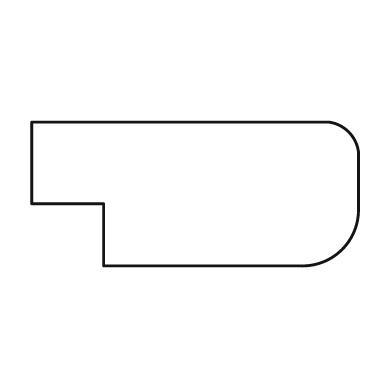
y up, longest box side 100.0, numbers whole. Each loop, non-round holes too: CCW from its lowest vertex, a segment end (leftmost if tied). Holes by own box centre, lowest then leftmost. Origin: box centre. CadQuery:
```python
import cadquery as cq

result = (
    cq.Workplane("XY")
    .moveTo(-28.0, -22.0)
    .lineTo(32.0, -22.0)
    .threePointArc((45.0, -17.0), (50.0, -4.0))
    .lineTo(50.0, 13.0)
    .threePointArc((47.0, 19.0), (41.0, 22.0))
    .lineTo(-50.0, 22.0)
    .lineTo(-50.0, -3.0)
    .lineTo(-28.0, -3.0)
    .close()
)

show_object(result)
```